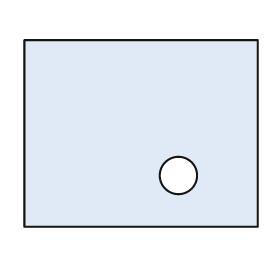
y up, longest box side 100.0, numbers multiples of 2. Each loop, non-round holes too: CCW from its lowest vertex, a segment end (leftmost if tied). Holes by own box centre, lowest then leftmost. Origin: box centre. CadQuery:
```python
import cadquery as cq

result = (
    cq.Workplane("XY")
    .moveTo(-50.0, -40.0)
    .lineTo(50.0, -40.0)
    .lineTo(50.0, 40.0)
    .lineTo(-50.0, 40.0)
    .close()
    .moveTo(16.0, -18.0)
    .circle(8.0)
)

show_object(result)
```